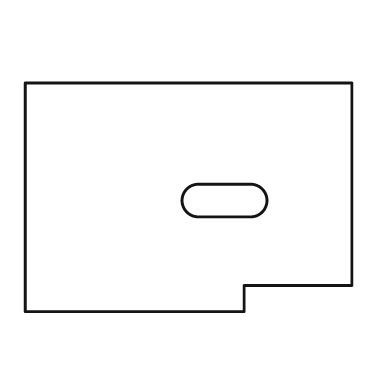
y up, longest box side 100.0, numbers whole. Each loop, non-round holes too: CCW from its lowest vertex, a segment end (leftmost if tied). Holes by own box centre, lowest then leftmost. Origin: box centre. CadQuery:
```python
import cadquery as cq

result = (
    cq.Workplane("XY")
    .moveTo(-50.0, -35.0)
    .lineTo(17.0, -35.0)
    .lineTo(17.0, -27.0)
    .lineTo(50.0, -27.0)
    .lineTo(50.0, 35.0)
    .lineTo(-50.0, 35.0)
    .close()
    .moveTo(3.0, -6.0)
    .lineTo(19.0, -6.0)
    .threePointArc((24.0, -1.0), (19.0, 4.0))
    .lineTo(3.0, 4.0)
    .threePointArc((-2.0, -1.0), (3.0, -6.0))
    .close()
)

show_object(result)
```